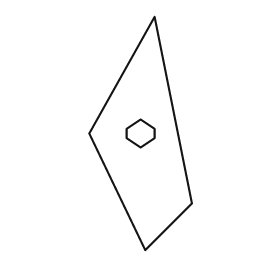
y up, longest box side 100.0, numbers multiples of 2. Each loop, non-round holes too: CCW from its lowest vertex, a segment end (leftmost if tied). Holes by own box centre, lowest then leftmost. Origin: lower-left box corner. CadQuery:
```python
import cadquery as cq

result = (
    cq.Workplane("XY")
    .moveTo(24.0, 0.0)
    .lineTo(44.0, 20.0)
    .lineTo(28.0, 100.0)
    .lineTo(0.0, 50.0)
    .close()
    .moveTo(22.0, 44.0)
    .lineTo(28.0, 48.0)
    .lineTo(28.0, 52.0)
    .lineTo(22.0, 56.0)
    .lineTo(16.0, 52.0)
    .lineTo(16.0, 48.0)
    .close()
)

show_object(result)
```